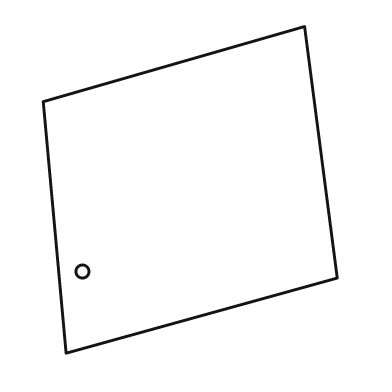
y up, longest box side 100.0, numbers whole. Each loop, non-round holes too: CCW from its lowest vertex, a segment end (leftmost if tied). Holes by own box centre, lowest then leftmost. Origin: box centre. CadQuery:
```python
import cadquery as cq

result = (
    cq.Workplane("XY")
    .moveTo(-38.0, -50.0)
    .lineTo(45.0, -27.0)
    .lineTo(35.0, 50.0)
    .lineTo(-45.0, 27.0)
    .close()
    .moveTo(-33.0, -25.0)
    .circle(2.0)
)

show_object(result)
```